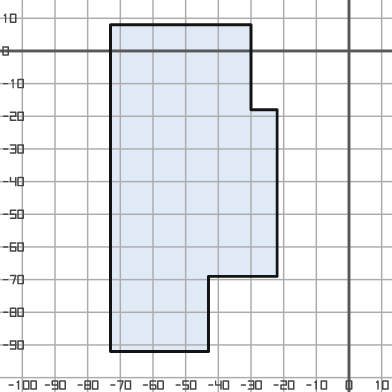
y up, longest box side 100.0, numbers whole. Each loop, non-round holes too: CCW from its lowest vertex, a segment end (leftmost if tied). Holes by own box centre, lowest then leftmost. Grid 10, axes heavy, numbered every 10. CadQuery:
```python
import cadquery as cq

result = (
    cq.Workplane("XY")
    .moveTo(-73.0, -92.0)
    .lineTo(-43.0, -92.0)
    .lineTo(-43.0, -69.0)
    .lineTo(-22.0, -69.0)
    .lineTo(-22.0, -18.0)
    .lineTo(-30.0, -18.0)
    .lineTo(-30.0, 8.0)
    .lineTo(-73.0, 8.0)
    .close()
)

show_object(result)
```